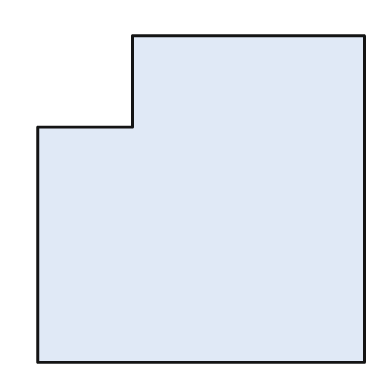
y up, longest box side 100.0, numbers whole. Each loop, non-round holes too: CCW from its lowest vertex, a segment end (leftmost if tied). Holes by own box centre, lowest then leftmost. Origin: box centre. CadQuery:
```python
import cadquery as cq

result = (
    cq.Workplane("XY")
    .moveTo(-50.0, -50.0)
    .lineTo(50.0, -50.0)
    .lineTo(50.0, 50.0)
    .lineTo(-21.0, 50.0)
    .lineTo(-21.0, 22.0)
    .lineTo(-50.0, 22.0)
    .close()
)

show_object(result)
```